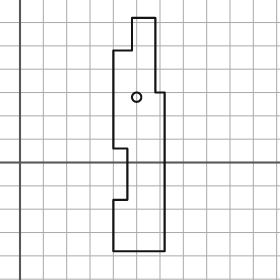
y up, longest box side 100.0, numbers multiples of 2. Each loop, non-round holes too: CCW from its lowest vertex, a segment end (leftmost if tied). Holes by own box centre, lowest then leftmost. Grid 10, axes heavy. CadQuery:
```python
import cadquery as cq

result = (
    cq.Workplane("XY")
    .moveTo(40.0, -38.0)
    .lineTo(62.0, -38.0)
    .lineTo(62.0, 30.0)
    .lineTo(58.0, 30.0)
    .lineTo(58.0, 62.0)
    .lineTo(48.0, 62.0)
    .lineTo(48.0, 48.0)
    .lineTo(40.0, 48.0)
    .lineTo(40.0, 6.0)
    .lineTo(46.0, 6.0)
    .lineTo(46.0, -16.0)
    .lineTo(40.0, -16.0)
    .close()
    .moveTo(50.0, 28.0)
    .circle(2.0)
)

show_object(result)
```